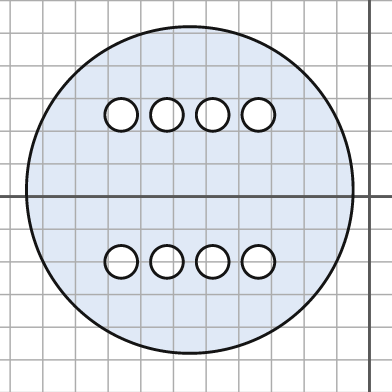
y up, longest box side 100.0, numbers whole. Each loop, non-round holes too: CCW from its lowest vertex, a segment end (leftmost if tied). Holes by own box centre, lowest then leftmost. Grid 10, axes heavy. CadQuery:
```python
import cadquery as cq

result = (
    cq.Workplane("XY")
    .moveTo(-55.0, 2.0)
    .circle(50.0)
    .moveTo(-76.0, -20.0)
    .circle(5.0)
    .moveTo(-62.0, -20.0)
    .circle(5.0)
    .moveTo(-48.0, -20.0)
    .circle(5.0)
    .moveTo(-34.0, -20.0)
    .circle(5.0)
    .moveTo(-76.0, 25.0)
    .circle(5.0)
    .moveTo(-62.0, 25.0)
    .circle(5.0)
    .moveTo(-48.0, 25.0)
    .circle(5.0)
    .moveTo(-34.0, 25.0)
    .circle(5.0)
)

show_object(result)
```